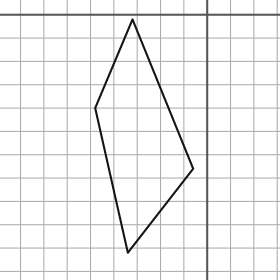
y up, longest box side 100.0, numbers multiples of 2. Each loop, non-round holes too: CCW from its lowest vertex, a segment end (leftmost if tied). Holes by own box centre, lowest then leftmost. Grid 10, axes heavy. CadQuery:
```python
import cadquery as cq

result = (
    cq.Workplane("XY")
    .moveTo(-34.0, -102.0)
    .lineTo(-6.0, -66.0)
    .lineTo(-32.0, -2.0)
    .lineTo(-48.0, -40.0)
    .close()
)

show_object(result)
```